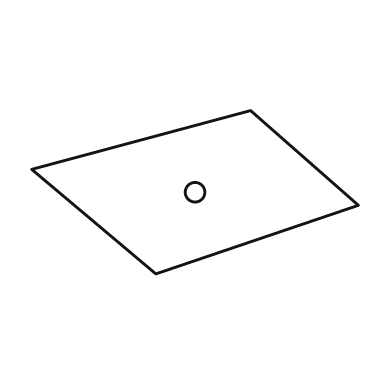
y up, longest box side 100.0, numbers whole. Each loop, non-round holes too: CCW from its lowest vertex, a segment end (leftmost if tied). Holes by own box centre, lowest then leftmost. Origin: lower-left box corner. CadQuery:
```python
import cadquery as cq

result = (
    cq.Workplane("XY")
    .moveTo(38.0, 0.0)
    .lineTo(100.0, 21.0)
    .lineTo(67.0, 50.0)
    .lineTo(0.0, 32.0)
    .close()
    .moveTo(50.0, 25.0)
    .circle(3.0)
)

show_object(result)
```